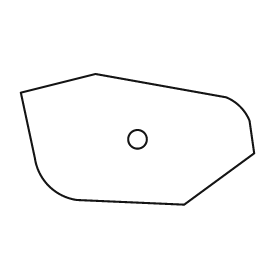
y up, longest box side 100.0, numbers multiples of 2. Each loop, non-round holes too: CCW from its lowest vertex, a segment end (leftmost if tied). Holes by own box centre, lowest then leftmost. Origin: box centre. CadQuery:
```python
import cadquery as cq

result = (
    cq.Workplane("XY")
    .moveTo(20.0, -28.0)
    .lineTo(50.0, -6.0)
    .lineTo(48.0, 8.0)
    .threePointArc((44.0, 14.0), (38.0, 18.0))
    .lineTo(-18.0, 28.0)
    .lineTo(-50.0, 20.0)
    .lineTo(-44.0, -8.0)
    .threePointArc((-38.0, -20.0), (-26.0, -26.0))
    .close()
    .moveTo(0.0, 0.0)
    .circle(4.0)
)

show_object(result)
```